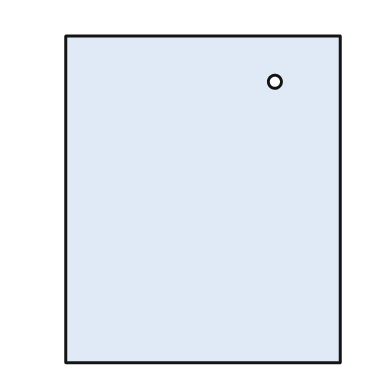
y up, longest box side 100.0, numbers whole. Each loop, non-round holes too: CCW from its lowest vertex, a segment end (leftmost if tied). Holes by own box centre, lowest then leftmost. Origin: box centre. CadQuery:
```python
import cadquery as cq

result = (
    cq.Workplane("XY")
    .moveTo(-42.0, -50.0)
    .lineTo(42.0, -50.0)
    .lineTo(42.0, 50.0)
    .lineTo(-42.0, 50.0)
    .close()
    .moveTo(22.0, 36.0)
    .circle(2.0)
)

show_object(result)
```